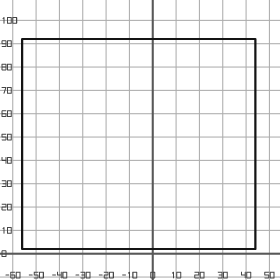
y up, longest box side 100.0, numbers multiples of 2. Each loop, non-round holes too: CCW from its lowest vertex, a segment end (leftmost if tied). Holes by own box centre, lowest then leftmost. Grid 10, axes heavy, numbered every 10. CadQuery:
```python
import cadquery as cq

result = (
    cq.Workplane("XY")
    .moveTo(-56.0, 2.0)
    .lineTo(44.0, 2.0)
    .lineTo(44.0, 92.0)
    .lineTo(-56.0, 92.0)
    .close()
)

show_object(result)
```